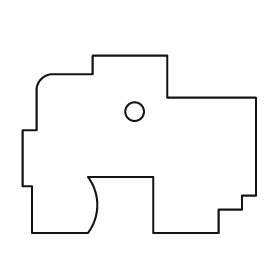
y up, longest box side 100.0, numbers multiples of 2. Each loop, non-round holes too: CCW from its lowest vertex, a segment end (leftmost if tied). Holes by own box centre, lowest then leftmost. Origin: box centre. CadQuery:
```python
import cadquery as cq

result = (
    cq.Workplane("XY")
    .moveTo(-46.0, -38.0)
    .lineTo(-22.0, -38.0)
    .threePointArc((-18.0, -26.0), (-22.0, -14.0))
    .lineTo(6.0, -14.0)
    .lineTo(6.0, -38.0)
    .lineTo(34.0, -38.0)
    .lineTo(34.0, -28.0)
    .lineTo(44.0, -28.0)
    .lineTo(44.0, -22.0)
    .lineTo(50.0, -22.0)
    .lineTo(50.0, 20.0)
    .lineTo(12.0, 20.0)
    .lineTo(12.0, 38.0)
    .lineTo(-20.0, 38.0)
    .lineTo(-20.0, 30.0)
    .lineTo(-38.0, 30.0)
    .threePointArc((-42.0, 28.0), (-44.0, 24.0))
    .lineTo(-44.0, 6.0)
    .lineTo(-50.0, 6.0)
    .lineTo(-50.0, -18.0)
    .lineTo(-46.0, -18.0)
    .close()
    .moveTo(-2.0, 14.0)
    .circle(4.0)
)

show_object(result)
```